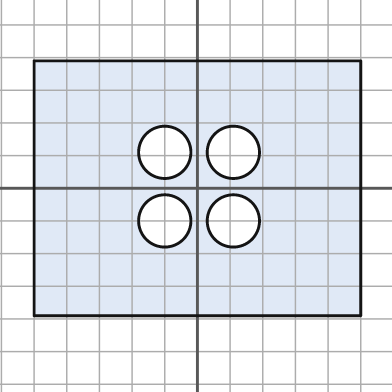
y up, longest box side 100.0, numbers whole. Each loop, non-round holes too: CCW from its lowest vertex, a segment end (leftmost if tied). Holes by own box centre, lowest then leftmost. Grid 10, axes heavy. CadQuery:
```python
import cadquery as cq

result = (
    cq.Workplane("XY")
    .moveTo(-50.0, -39.0)
    .lineTo(50.0, -39.0)
    .lineTo(50.0, 39.0)
    .lineTo(-50.0, 39.0)
    .close()
    .moveTo(-10.0, -10.0)
    .circle(8.0)
    .moveTo(11.0, -10.0)
    .circle(8.0)
    .moveTo(-10.0, 11.0)
    .circle(8.0)
    .moveTo(11.0, 11.0)
    .circle(8.0)
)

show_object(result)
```